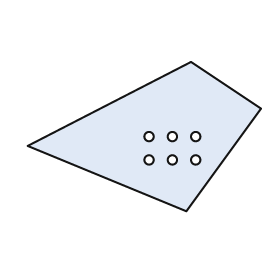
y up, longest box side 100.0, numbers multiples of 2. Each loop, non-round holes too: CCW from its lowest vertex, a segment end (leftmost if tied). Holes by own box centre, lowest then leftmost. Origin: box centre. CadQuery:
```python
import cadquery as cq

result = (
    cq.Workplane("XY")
    .moveTo(18.0, -32.0)
    .lineTo(50.0, 12.0)
    .lineTo(20.0, 32.0)
    .lineTo(-50.0, -4.0)
    .close()
    .moveTo(2.0, -10.0)
    .circle(2.0)
    .moveTo(12.0, -10.0)
    .circle(2.0)
    .moveTo(22.0, -10.0)
    .circle(2.0)
    .moveTo(2.0, 0.0)
    .circle(2.0)
    .moveTo(12.0, 0.0)
    .circle(2.0)
    .moveTo(22.0, 0.0)
    .circle(2.0)
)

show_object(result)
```